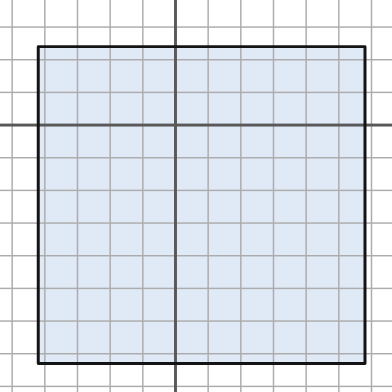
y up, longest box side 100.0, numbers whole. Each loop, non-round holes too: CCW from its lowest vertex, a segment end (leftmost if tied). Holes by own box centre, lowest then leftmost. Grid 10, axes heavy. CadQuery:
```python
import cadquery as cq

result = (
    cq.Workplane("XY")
    .moveTo(-42.0, -73.0)
    .lineTo(58.0, -73.0)
    .lineTo(58.0, 24.0)
    .lineTo(-42.0, 24.0)
    .close()
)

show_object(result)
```